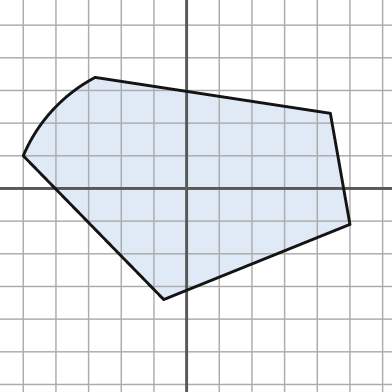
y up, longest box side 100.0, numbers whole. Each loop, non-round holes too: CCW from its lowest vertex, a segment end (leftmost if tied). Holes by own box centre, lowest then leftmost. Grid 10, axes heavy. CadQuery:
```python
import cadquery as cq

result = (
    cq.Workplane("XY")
    .moveTo(-7.0, -34.0)
    .lineTo(50.0, -11.0)
    .lineTo(44.0, 23.0)
    .lineTo(-28.0, 34.0)
    .threePointArc((-41.0, 24.0), (-50.0, 10.0))
    .close()
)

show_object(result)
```